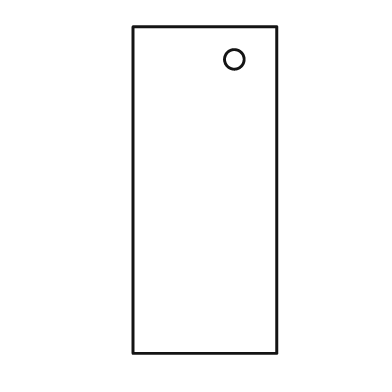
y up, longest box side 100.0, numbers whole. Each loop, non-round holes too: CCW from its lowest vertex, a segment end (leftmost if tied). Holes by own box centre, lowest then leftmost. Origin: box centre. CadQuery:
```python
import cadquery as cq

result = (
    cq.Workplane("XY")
    .moveTo(-22.0, -50.0)
    .lineTo(22.0, -50.0)
    .lineTo(22.0, 50.0)
    .lineTo(-22.0, 50.0)
    .close()
    .moveTo(9.0, 40.0)
    .circle(3.0)
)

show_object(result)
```